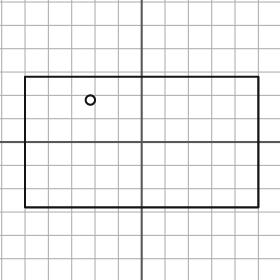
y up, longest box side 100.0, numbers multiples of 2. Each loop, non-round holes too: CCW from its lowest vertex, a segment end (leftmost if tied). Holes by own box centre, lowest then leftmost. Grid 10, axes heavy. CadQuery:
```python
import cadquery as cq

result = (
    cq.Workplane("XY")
    .moveTo(-50.0, -28.0)
    .lineTo(50.0, -28.0)
    .lineTo(50.0, 28.0)
    .lineTo(-50.0, 28.0)
    .close()
    .moveTo(-22.0, 18.0)
    .circle(2.0)
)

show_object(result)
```